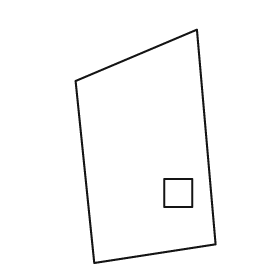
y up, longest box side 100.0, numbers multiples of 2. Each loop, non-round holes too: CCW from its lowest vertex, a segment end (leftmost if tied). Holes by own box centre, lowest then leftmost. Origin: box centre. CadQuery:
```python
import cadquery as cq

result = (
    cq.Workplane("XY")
    .moveTo(-22.0, -50.0)
    .lineTo(30.0, -42.0)
    .lineTo(22.0, 50.0)
    .lineTo(-30.0, 28.0)
    .close()
    .moveTo(8.0, -26.0)
    .lineTo(20.0, -26.0)
    .lineTo(20.0, -14.0)
    .lineTo(8.0, -14.0)
    .close()
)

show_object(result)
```